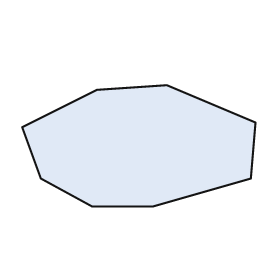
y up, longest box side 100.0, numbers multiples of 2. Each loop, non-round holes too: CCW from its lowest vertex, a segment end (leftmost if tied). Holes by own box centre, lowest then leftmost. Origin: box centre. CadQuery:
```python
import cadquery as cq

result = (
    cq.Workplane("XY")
    .moveTo(-20.0, -26.0)
    .lineTo(6.0, -26.0)
    .lineTo(48.0, -14.0)
    .lineTo(50.0, 10.0)
    .lineTo(12.0, 26.0)
    .lineTo(-18.0, 24.0)
    .lineTo(-50.0, 8.0)
    .lineTo(-42.0, -14.0)
    .close()
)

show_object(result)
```